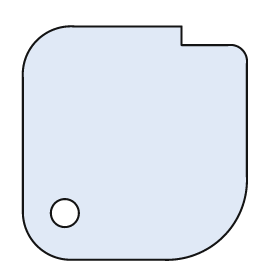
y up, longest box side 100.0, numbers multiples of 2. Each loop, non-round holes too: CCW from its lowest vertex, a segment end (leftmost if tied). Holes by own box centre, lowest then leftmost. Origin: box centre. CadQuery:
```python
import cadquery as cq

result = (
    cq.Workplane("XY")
    .moveTo(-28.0, -50.0)
    .lineTo(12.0, -50.0)
    .threePointArc((38.0, -40.0), (48.0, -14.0))
    .lineTo(48.0, 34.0)
    .threePointArc((46.0, 40.0), (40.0, 42.0))
    .lineTo(20.0, 42.0)
    .lineTo(20.0, 50.0)
    .lineTo(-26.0, 50.0)
    .threePointArc((-42.0, 44.0), (-48.0, 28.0))
    .lineTo(-48.0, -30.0)
    .threePointArc((-42.0, -44.0), (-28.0, -50.0))
    .close()
    .moveTo(-30.0, -30.0)
    .circle(6.0)
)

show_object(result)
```